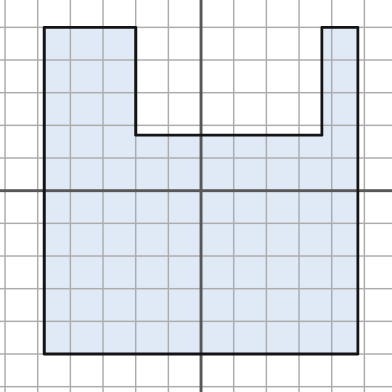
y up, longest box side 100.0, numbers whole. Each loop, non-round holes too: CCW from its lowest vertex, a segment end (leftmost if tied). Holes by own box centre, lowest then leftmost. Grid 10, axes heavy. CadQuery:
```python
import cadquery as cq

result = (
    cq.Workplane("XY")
    .moveTo(-48.0, -50.0)
    .lineTo(48.0, -50.0)
    .lineTo(48.0, 50.0)
    .lineTo(37.0, 50.0)
    .lineTo(37.0, 17.0)
    .lineTo(-20.0, 17.0)
    .lineTo(-20.0, 50.0)
    .lineTo(-48.0, 50.0)
    .close()
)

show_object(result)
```